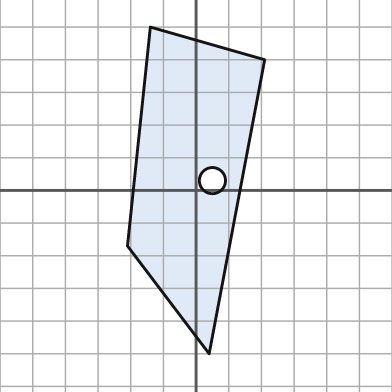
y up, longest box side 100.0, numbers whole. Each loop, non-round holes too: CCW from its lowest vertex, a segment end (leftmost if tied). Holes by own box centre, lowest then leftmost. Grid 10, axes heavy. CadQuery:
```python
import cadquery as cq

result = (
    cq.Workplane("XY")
    .moveTo(4.0, -50.0)
    .lineTo(21.0, 40.0)
    .lineTo(-14.0, 50.0)
    .lineTo(-21.0, -17.0)
    .close()
    .moveTo(5.0, 3.0)
    .circle(4.0)
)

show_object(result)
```